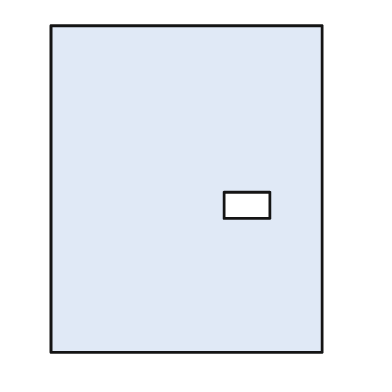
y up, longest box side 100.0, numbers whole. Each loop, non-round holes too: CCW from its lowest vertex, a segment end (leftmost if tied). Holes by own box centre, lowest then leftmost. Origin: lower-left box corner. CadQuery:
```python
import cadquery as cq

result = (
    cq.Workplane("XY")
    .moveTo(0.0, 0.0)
    .lineTo(83.0, 0.0)
    .lineTo(83.0, 100.0)
    .lineTo(0.0, 100.0)
    .close()
    .moveTo(53.0, 41.0)
    .lineTo(67.0, 41.0)
    .lineTo(67.0, 49.0)
    .lineTo(53.0, 49.0)
    .close()
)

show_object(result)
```